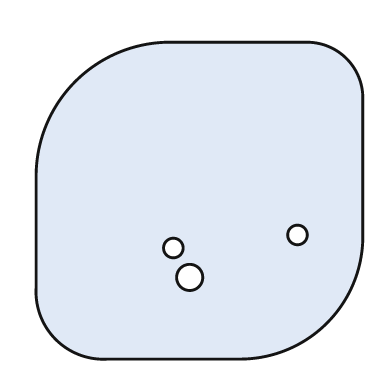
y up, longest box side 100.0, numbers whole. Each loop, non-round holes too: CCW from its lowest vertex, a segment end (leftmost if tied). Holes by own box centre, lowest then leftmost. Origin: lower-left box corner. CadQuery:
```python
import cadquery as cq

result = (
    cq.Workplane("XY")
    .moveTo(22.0, 0.0)
    .lineTo(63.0, 0.0)
    .threePointArc((89.0, 11.0), (100.0, 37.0))
    .lineTo(100.0, 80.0)
    .threePointArc((95.0, 92.0), (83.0, 97.0))
    .lineTo(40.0, 97.0)
    .threePointArc((12.0, 85.0), (0.0, 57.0))
    .lineTo(0.0, 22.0)
    .threePointArc((6.0, 6.0), (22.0, 0.0))
    .close()
    .moveTo(47.0, 25.0)
    .circle(4.0)
    .moveTo(42.0, 34.0)
    .circle(3.0)
    .moveTo(80.0, 38.0)
    .circle(3.0)
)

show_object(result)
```